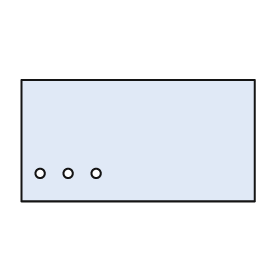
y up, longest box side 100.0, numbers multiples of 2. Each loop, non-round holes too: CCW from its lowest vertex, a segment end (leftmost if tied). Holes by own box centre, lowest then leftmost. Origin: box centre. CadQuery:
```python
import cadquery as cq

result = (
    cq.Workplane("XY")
    .moveTo(-50.0, -26.0)
    .lineTo(50.0, -26.0)
    .lineTo(50.0, 26.0)
    .lineTo(-50.0, 26.0)
    .close()
    .moveTo(-42.0, -14.0)
    .circle(2.0)
    .moveTo(-30.0, -14.0)
    .circle(2.0)
    .moveTo(-18.0, -14.0)
    .circle(2.0)
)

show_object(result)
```